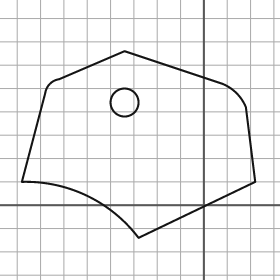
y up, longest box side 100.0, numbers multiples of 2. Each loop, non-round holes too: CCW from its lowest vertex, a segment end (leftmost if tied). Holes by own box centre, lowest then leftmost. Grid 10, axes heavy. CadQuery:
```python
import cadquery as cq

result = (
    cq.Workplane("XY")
    .moveTo(-28.0, -14.0)
    .lineTo(22.0, 10.0)
    .lineTo(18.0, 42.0)
    .threePointArc((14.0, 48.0), (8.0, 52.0))
    .lineTo(-34.0, 66.0)
    .lineTo(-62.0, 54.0)
    .threePointArc((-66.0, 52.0), (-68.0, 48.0))
    .lineTo(-78.0, 10.0)
    .threePointArc((-50.0, 4.0), (-28.0, -14.0))
    .close()
    .moveTo(-34.0, 44.0)
    .circle(6.0)
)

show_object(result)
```